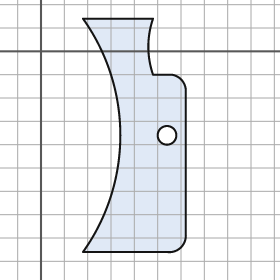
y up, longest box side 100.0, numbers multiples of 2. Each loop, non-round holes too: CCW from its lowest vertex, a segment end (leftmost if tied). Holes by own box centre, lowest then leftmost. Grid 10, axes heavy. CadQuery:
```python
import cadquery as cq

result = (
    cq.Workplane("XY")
    .moveTo(18.0, -86.0)
    .lineTo(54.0, -86.0)
    .threePointArc((60.0, -84.0), (62.0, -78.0))
    .lineTo(62.0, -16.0)
    .threePointArc((60.0, -12.0), (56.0, -10.0))
    .lineTo(48.0, -10.0)
    .threePointArc((46.0, 2.0), (48.0, 14.0))
    .lineTo(18.0, 14.0)
    .threePointArc((34.0, -36.0), (18.0, -86.0))
    .close()
    .moveTo(54.0, -36.0)
    .circle(4.0)
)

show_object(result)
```